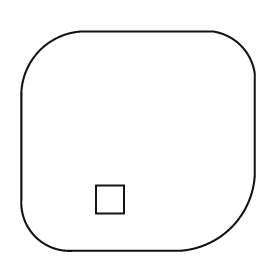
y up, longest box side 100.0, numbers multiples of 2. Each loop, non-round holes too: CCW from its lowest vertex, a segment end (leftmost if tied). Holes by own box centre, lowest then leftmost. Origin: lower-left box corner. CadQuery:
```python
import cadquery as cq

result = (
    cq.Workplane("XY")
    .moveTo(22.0, 0.0)
    .lineTo(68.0, 0.0)
    .threePointArc((90.0, 10.0), (100.0, 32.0))
    .lineTo(100.0, 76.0)
    .threePointArc((94.0, 88.0), (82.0, 94.0))
    .lineTo(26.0, 94.0)
    .threePointArc((8.0, 86.0), (0.0, 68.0))
    .lineTo(0.0, 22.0)
    .threePointArc((6.0, 6.0), (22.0, 0.0))
    .close()
    .moveTo(32.0, 16.0)
    .lineTo(44.0, 16.0)
    .lineTo(44.0, 28.0)
    .lineTo(32.0, 28.0)
    .close()
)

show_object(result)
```